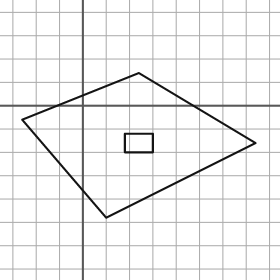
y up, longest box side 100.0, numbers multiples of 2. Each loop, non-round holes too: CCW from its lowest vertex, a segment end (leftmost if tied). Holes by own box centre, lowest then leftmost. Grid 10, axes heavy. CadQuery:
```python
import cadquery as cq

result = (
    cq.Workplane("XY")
    .moveTo(10.0, -48.0)
    .lineTo(74.0, -16.0)
    .lineTo(24.0, 14.0)
    .lineTo(-26.0, -6.0)
    .close()
    .moveTo(18.0, -20.0)
    .lineTo(30.0, -20.0)
    .lineTo(30.0, -12.0)
    .lineTo(18.0, -12.0)
    .close()
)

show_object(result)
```